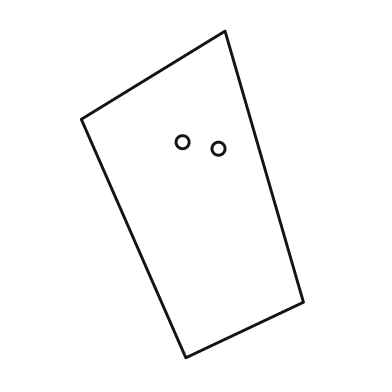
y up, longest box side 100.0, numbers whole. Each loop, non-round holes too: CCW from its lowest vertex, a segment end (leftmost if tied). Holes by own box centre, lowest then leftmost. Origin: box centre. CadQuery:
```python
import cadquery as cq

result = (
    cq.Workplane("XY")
    .moveTo(-2.0, -50.0)
    .lineTo(34.0, -33.0)
    .lineTo(10.0, 50.0)
    .lineTo(-34.0, 23.0)
    .close()
    .moveTo(8.0, 14.0)
    .circle(2.0)
    .moveTo(-3.0, 16.0)
    .circle(2.0)
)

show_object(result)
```